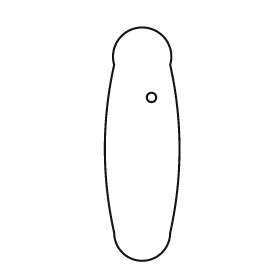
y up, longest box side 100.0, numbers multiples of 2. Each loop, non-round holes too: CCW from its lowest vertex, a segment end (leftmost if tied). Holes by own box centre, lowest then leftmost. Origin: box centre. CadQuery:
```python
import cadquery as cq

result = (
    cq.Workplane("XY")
    .moveTo(-12.0, -38.0)
    .threePointArc((0.0, -50.0), (12.0, -38.0))
    .threePointArc((16.0, -2.0), (12.0, 34.0))
    .threePointArc((0.0, 50.0), (-12.0, 34.0))
    .threePointArc((-16.0, -2.0), (-12.0, -38.0))
    .close()
    .moveTo(4.0, 20.0)
    .circle(2.0)
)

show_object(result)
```